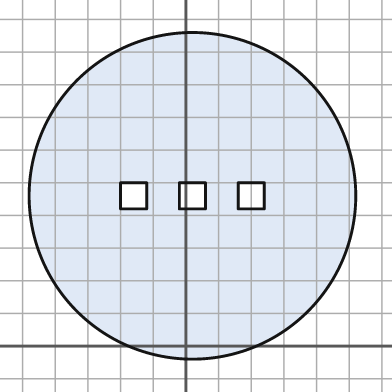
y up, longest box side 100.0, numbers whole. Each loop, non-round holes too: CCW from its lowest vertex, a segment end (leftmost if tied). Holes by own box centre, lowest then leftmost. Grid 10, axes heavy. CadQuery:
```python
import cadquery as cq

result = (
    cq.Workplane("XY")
    .moveTo(2.0, 46.0)
    .circle(50.0)
    .moveTo(-20.0, 42.0)
    .lineTo(-12.0, 42.0)
    .lineTo(-12.0, 50.0)
    .lineTo(-20.0, 50.0)
    .close()
    .moveTo(-2.0, 42.0)
    .lineTo(6.0, 42.0)
    .lineTo(6.0, 50.0)
    .lineTo(-2.0, 50.0)
    .close()
    .moveTo(16.0, 42.0)
    .lineTo(24.0, 42.0)
    .lineTo(24.0, 50.0)
    .lineTo(16.0, 50.0)
    .close()
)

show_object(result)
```